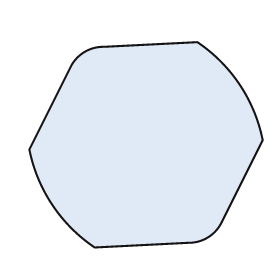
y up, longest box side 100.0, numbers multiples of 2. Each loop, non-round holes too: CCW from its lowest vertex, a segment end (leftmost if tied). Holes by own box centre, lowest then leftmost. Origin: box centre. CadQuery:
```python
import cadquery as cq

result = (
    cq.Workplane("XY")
    .moveTo(-22.0, -44.0)
    .lineTo(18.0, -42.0)
    .threePointArc((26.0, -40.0), (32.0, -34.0))
    .lineTo(50.0, 2.0)
    .threePointArc((40.0, 26.0), (22.0, 44.0))
    .lineTo(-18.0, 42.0)
    .threePointArc((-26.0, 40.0), (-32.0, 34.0))
    .lineTo(-50.0, -2.0)
    .threePointArc((-40.0, -26.0), (-22.0, -44.0))
    .close()
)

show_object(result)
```